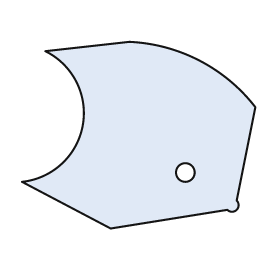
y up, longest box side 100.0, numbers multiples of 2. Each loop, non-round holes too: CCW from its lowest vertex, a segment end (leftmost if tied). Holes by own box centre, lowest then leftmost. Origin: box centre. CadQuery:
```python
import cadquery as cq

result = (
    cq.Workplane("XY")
    .moveTo(-12.0, -40.0)
    .lineTo(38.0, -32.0)
    .threePointArc((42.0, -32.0), (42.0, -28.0))
    .lineTo(50.0, 12.0)
    .threePointArc((26.0, 32.0), (-4.0, 40.0))
    .lineTo(-40.0, 36.0)
    .threePointArc((-24.0, 4.0), (-50.0, -20.0))
    .close()
    .moveTo(20.0, -16.0)
    .circle(4.0)
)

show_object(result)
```